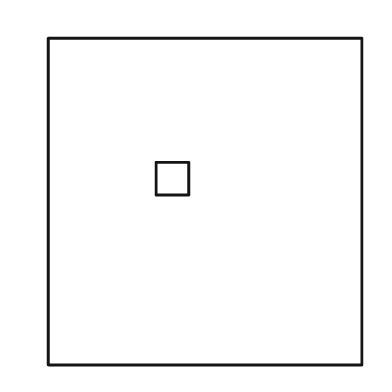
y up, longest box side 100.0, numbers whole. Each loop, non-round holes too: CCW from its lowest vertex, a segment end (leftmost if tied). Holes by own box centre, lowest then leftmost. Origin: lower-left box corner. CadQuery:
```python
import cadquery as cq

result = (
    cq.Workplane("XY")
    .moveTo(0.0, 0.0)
    .lineTo(96.0, 0.0)
    .lineTo(96.0, 100.0)
    .lineTo(0.0, 100.0)
    .close()
    .moveTo(33.0, 52.0)
    .lineTo(43.0, 52.0)
    .lineTo(43.0, 62.0)
    .lineTo(33.0, 62.0)
    .close()
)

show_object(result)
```